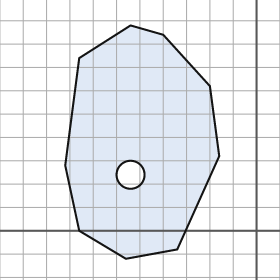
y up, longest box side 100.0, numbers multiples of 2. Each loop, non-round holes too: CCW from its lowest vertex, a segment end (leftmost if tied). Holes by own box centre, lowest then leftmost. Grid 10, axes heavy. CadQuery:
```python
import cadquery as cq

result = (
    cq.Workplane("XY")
    .moveTo(-56.0, -12.0)
    .lineTo(-34.0, -8.0)
    .lineTo(-16.0, 32.0)
    .lineTo(-20.0, 62.0)
    .lineTo(-40.0, 84.0)
    .lineTo(-54.0, 88.0)
    .lineTo(-76.0, 74.0)
    .lineTo(-82.0, 28.0)
    .lineTo(-76.0, 0.0)
    .close()
    .moveTo(-54.0, 24.0)
    .circle(6.0)
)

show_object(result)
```